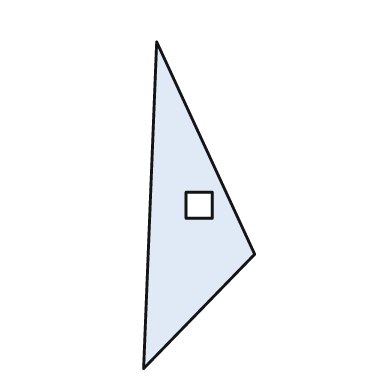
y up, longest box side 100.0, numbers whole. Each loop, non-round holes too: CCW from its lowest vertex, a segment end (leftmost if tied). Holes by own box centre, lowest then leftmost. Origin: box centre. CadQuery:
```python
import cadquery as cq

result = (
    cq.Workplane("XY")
    .moveTo(-17.0, -50.0)
    .lineTo(17.0, -15.0)
    .lineTo(-13.0, 50.0)
    .close()
    .moveTo(-4.0, -4.0)
    .lineTo(4.0, -4.0)
    .lineTo(4.0, 4.0)
    .lineTo(-4.0, 4.0)
    .close()
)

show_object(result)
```